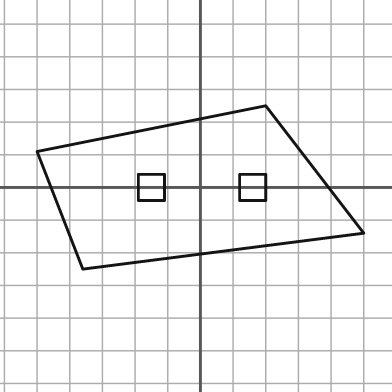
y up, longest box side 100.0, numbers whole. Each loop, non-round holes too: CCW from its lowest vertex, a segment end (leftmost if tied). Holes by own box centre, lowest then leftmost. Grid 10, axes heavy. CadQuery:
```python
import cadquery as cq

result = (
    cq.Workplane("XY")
    .moveTo(-36.0, -25.0)
    .lineTo(50.0, -14.0)
    .lineTo(20.0, 25.0)
    .lineTo(-50.0, 11.0)
    .close()
    .moveTo(-19.0, -4.0)
    .lineTo(-11.0, -4.0)
    .lineTo(-11.0, 4.0)
    .lineTo(-19.0, 4.0)
    .close()
    .moveTo(12.0, -4.0)
    .lineTo(20.0, -4.0)
    .lineTo(20.0, 4.0)
    .lineTo(12.0, 4.0)
    .close()
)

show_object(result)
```